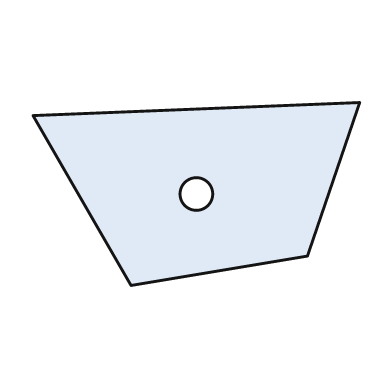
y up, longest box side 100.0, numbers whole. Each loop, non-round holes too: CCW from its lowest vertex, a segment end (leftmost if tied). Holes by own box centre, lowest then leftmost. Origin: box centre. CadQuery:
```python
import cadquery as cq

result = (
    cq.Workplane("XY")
    .moveTo(-20.0, -28.0)
    .lineTo(34.0, -19.0)
    .lineTo(50.0, 28.0)
    .lineTo(-50.0, 24.0)
    .close()
    .moveTo(0.0, 0.0)
    .circle(5.0)
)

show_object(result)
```